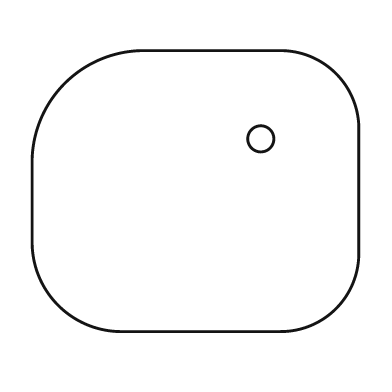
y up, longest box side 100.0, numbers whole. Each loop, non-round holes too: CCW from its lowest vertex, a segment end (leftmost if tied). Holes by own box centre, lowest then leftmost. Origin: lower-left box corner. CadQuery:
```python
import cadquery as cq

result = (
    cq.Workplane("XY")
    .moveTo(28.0, 0.0)
    .lineTo(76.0, 0.0)
    .threePointArc((93.0, 7.0), (100.0, 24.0))
    .lineTo(100.0, 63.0)
    .threePointArc((93.0, 79.0), (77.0, 86.0))
    .lineTo(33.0, 86.0)
    .threePointArc((10.0, 76.0), (0.0, 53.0))
    .lineTo(0.0, 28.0)
    .threePointArc((8.0, 8.0), (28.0, 0.0))
    .close()
    .moveTo(70.0, 59.0)
    .circle(4.0)
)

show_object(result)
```